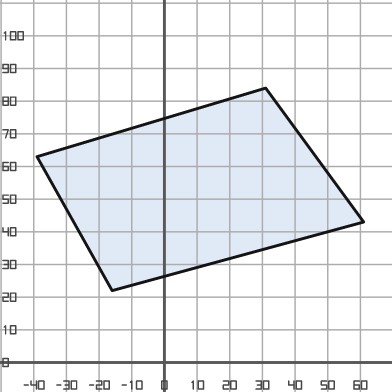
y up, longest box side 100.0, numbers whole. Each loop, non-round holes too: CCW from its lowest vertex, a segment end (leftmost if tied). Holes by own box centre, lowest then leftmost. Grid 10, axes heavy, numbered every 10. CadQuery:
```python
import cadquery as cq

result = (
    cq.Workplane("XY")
    .moveTo(-16.0, 22.0)
    .lineTo(61.0, 43.0)
    .lineTo(31.0, 84.0)
    .lineTo(-39.0, 63.0)
    .close()
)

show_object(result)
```